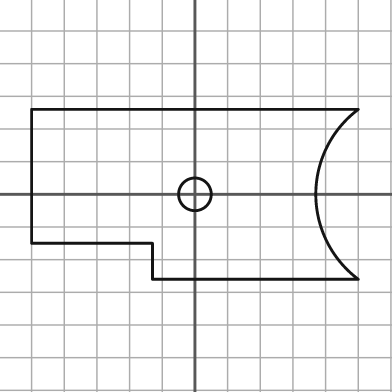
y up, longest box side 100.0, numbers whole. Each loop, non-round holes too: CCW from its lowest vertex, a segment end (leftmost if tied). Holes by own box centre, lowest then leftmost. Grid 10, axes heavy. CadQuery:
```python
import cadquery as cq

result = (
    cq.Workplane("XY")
    .moveTo(-13.0, -26.0)
    .lineTo(50.0, -26.0)
    .threePointArc((37.0, 0.0), (50.0, 26.0))
    .lineTo(-50.0, 26.0)
    .lineTo(-50.0, -15.0)
    .lineTo(-13.0, -15.0)
    .close()
    .moveTo(0.0, 0.0)
    .circle(5.0)
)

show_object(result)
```